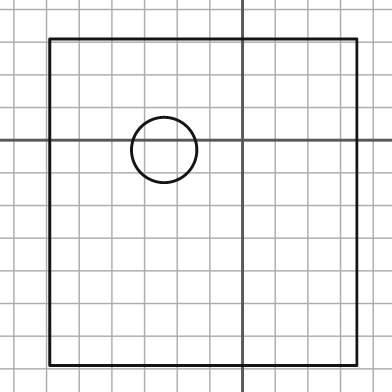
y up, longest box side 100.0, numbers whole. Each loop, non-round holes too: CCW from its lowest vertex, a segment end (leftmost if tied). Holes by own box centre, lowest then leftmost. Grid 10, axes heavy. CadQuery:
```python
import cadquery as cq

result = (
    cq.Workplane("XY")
    .moveTo(-59.0, -69.0)
    .lineTo(35.0, -69.0)
    .lineTo(35.0, 31.0)
    .lineTo(-59.0, 31.0)
    .close()
    .moveTo(-24.0, -3.0)
    .circle(10.0)
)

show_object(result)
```